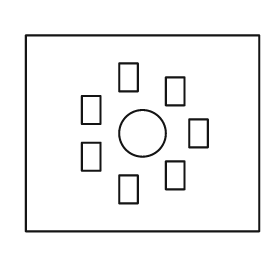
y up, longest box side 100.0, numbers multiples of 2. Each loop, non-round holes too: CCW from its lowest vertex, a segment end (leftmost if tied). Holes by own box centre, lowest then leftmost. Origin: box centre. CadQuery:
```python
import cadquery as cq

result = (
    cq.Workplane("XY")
    .moveTo(-50.0, -42.0)
    .lineTo(50.0, -42.0)
    .lineTo(50.0, 42.0)
    .lineTo(-50.0, 42.0)
    .close()
    .moveTo(-10.0, -30.0)
    .lineTo(-2.0, -30.0)
    .lineTo(-2.0, -18.0)
    .lineTo(-10.0, -18.0)
    .close()
    .moveTo(10.0, -24.0)
    .lineTo(18.0, -24.0)
    .lineTo(18.0, -12.0)
    .lineTo(10.0, -12.0)
    .close()
    .moveTo(-26.0, -16.0)
    .lineTo(-18.0, -16.0)
    .lineTo(-18.0, -4.0)
    .lineTo(-26.0, -4.0)
    .close()
    .moveTo(0.0, 0.0)
    .circle(10.0)
    .moveTo(20.0, -6.0)
    .lineTo(28.0, -6.0)
    .lineTo(28.0, 6.0)
    .lineTo(20.0, 6.0)
    .close()
    .moveTo(-26.0, 4.0)
    .lineTo(-18.0, 4.0)
    .lineTo(-18.0, 16.0)
    .lineTo(-26.0, 16.0)
    .close()
    .moveTo(10.0, 12.0)
    .lineTo(18.0, 12.0)
    .lineTo(18.0, 24.0)
    .lineTo(10.0, 24.0)
    .close()
    .moveTo(-10.0, 18.0)
    .lineTo(-2.0, 18.0)
    .lineTo(-2.0, 30.0)
    .lineTo(-10.0, 30.0)
    .close()
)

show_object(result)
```